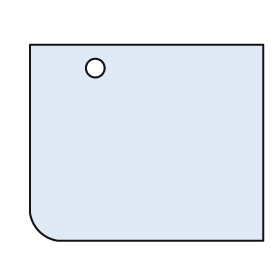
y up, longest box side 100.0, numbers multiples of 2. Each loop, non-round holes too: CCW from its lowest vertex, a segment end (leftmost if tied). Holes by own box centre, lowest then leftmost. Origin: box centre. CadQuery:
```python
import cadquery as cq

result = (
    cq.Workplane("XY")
    .moveTo(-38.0, -42.0)
    .lineTo(50.0, -42.0)
    .lineTo(50.0, 42.0)
    .lineTo(-50.0, 42.0)
    .lineTo(-50.0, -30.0)
    .threePointArc((-46.0, -38.0), (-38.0, -42.0))
    .close()
    .moveTo(-22.0, 32.0)
    .circle(4.0)
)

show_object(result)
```